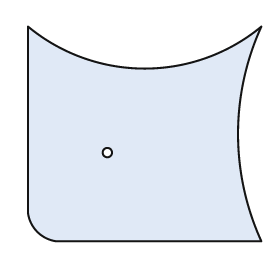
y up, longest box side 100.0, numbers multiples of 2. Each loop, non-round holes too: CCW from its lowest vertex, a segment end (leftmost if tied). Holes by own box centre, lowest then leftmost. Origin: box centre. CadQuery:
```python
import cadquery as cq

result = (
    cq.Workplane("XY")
    .moveTo(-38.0, -46.0)
    .lineTo(50.0, -46.0)
    .threePointArc((40.0, 0.0), (50.0, 46.0))
    .threePointArc((0.0, 28.0), (-50.0, 46.0))
    .lineTo(-50.0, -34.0)
    .threePointArc((-46.0, -42.0), (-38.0, -46.0))
    .close()
    .moveTo(-16.0, -8.0)
    .circle(2.0)
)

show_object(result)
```